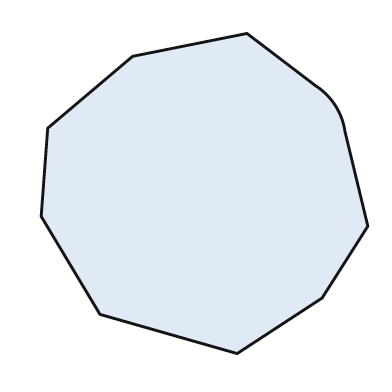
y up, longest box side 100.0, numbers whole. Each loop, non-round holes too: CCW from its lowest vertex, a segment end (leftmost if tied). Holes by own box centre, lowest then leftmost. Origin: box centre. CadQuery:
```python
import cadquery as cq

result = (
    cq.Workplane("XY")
    .moveTo(10.0, -49.0)
    .lineTo(36.0, -32.0)
    .lineTo(50.0, -10.0)
    .lineTo(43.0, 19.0)
    .threePointArc((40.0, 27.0), (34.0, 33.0))
    .lineTo(13.0, 49.0)
    .lineTo(-22.0, 42.0)
    .lineTo(-48.0, 20.0)
    .lineTo(-50.0, -7.0)
    .lineTo(-32.0, -37.0)
    .close()
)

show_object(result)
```